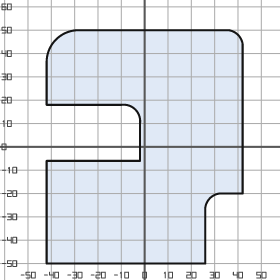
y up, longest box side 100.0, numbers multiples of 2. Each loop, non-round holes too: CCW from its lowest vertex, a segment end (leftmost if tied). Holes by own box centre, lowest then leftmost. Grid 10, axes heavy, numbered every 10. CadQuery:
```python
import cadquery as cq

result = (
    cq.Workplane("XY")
    .moveTo(-42.0, -50.0)
    .lineTo(26.0, -50.0)
    .lineTo(26.0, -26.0)
    .threePointArc((28.0, -22.0), (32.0, -20.0))
    .lineTo(42.0, -20.0)
    .lineTo(42.0, 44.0)
    .threePointArc((40.0, 48.0), (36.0, 50.0))
    .lineTo(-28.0, 50.0)
    .threePointArc((-38.0, 46.0), (-42.0, 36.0))
    .lineTo(-42.0, 18.0)
    .lineTo(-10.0, 18.0)
    .threePointArc((-4.0, 16.0), (-2.0, 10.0))
    .lineTo(-2.0, -6.0)
    .lineTo(-42.0, -6.0)
    .close()
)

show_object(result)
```